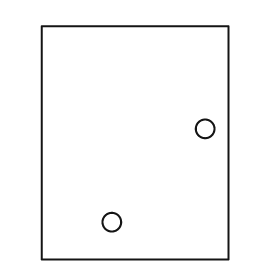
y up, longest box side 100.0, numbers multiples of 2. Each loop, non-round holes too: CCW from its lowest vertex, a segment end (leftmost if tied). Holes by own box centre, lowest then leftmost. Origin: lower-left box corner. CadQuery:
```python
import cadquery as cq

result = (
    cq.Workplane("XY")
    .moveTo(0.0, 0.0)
    .lineTo(80.0, 0.0)
    .lineTo(80.0, 100.0)
    .lineTo(0.0, 100.0)
    .close()
    .moveTo(30.0, 16.0)
    .circle(4.0)
    .moveTo(70.0, 56.0)
    .circle(4.0)
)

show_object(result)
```